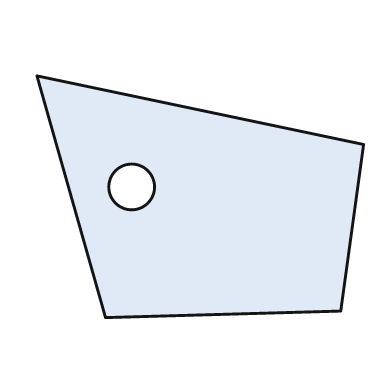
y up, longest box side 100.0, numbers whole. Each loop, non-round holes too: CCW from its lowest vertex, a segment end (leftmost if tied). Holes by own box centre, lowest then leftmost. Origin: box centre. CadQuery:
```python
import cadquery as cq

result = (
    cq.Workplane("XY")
    .moveTo(-29.0, -37.0)
    .lineTo(43.0, -35.0)
    .lineTo(50.0, 16.0)
    .lineTo(-50.0, 37.0)
    .close()
    .moveTo(-21.0, 3.0)
    .circle(7.0)
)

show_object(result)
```